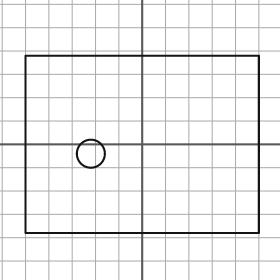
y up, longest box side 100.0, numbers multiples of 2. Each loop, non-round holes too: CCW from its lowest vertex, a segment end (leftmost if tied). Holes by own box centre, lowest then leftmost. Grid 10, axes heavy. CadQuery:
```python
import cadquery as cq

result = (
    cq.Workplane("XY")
    .moveTo(-50.0, -38.0)
    .lineTo(50.0, -38.0)
    .lineTo(50.0, 38.0)
    .lineTo(-50.0, 38.0)
    .close()
    .moveTo(-22.0, -4.0)
    .circle(6.0)
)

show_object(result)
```